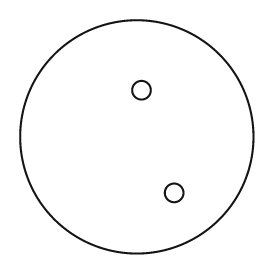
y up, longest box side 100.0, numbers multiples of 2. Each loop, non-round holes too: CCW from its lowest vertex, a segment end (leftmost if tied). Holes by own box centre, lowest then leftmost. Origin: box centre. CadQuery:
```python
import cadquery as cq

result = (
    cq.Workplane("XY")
    .moveTo(0.0, 0.0)
    .circle(50.0)
    .moveTo(16.0, -24.0)
    .circle(4.0)
    .moveTo(2.0, 20.0)
    .circle(4.0)
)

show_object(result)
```